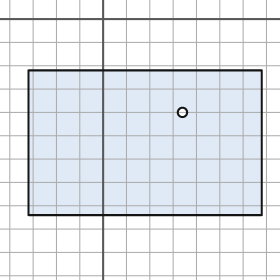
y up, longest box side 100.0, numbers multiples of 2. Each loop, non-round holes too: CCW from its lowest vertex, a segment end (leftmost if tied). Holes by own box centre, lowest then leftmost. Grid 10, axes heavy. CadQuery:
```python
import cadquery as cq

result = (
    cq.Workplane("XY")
    .moveTo(-32.0, -84.0)
    .lineTo(68.0, -84.0)
    .lineTo(68.0, -22.0)
    .lineTo(-32.0, -22.0)
    .close()
    .moveTo(34.0, -40.0)
    .circle(2.0)
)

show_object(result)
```